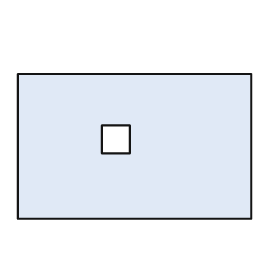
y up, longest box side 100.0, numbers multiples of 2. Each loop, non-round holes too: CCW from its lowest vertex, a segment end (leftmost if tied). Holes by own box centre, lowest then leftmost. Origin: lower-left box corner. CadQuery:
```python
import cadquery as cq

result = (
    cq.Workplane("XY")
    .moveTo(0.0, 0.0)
    .lineTo(100.0, 0.0)
    .lineTo(100.0, 62.0)
    .lineTo(0.0, 62.0)
    .close()
    .moveTo(36.0, 28.0)
    .lineTo(48.0, 28.0)
    .lineTo(48.0, 40.0)
    .lineTo(36.0, 40.0)
    .close()
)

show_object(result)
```